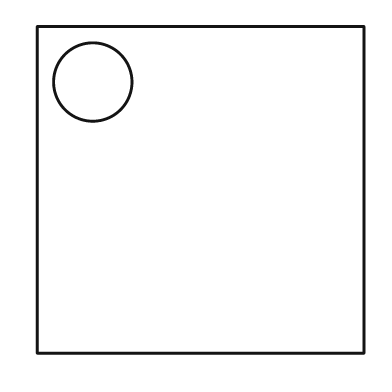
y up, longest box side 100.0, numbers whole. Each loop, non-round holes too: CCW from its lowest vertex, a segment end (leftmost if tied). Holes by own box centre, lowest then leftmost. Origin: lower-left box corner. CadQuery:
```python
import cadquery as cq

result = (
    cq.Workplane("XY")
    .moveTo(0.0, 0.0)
    .lineTo(100.0, 0.0)
    .lineTo(100.0, 100.0)
    .lineTo(0.0, 100.0)
    .close()
    .moveTo(17.0, 83.0)
    .circle(12.0)
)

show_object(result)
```